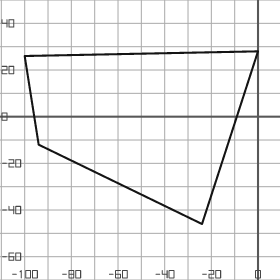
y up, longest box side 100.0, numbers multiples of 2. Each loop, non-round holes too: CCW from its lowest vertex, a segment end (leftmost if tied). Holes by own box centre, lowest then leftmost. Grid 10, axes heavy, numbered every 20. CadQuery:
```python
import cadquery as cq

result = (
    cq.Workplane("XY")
    .moveTo(-24.0, -46.0)
    .lineTo(0.0, 28.0)
    .lineTo(-100.0, 26.0)
    .lineTo(-94.0, -12.0)
    .close()
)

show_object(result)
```